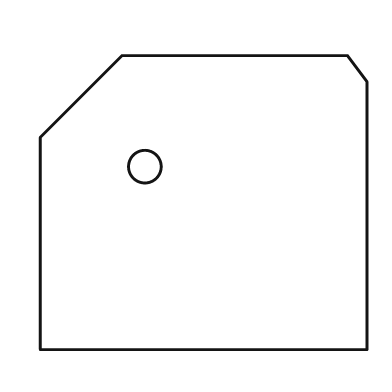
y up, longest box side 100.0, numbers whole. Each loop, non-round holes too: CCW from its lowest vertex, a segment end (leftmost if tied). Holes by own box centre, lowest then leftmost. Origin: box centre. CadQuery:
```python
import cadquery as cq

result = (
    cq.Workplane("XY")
    .moveTo(-50.0, -45.0)
    .lineTo(50.0, -45.0)
    .lineTo(50.0, 37.0)
    .lineTo(44.0, 45.0)
    .lineTo(-25.0, 45.0)
    .lineTo(-50.0, 20.0)
    .close()
    .moveTo(-18.0, 11.0)
    .circle(5.0)
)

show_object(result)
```